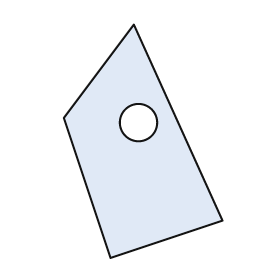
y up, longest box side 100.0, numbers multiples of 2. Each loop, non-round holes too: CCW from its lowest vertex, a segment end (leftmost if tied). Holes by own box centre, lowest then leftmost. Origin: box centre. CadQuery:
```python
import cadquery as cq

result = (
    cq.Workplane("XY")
    .moveTo(-14.0, -50.0)
    .lineTo(34.0, -34.0)
    .lineTo(-4.0, 50.0)
    .lineTo(-34.0, 10.0)
    .close()
    .moveTo(-2.0, 8.0)
    .circle(8.0)
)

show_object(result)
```